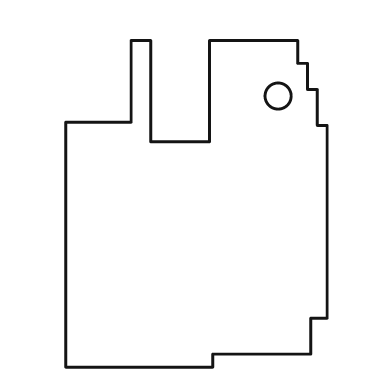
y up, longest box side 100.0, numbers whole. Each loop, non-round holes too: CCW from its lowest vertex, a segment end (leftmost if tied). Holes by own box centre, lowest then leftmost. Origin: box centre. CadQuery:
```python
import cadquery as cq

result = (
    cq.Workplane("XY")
    .moveTo(-40.0, -50.0)
    .lineTo(5.0, -50.0)
    .lineTo(5.0, -46.0)
    .lineTo(35.0, -46.0)
    .lineTo(35.0, -35.0)
    .lineTo(40.0, -35.0)
    .lineTo(40.0, 24.0)
    .lineTo(37.0, 24.0)
    .lineTo(37.0, 35.0)
    .lineTo(34.0, 35.0)
    .lineTo(34.0, 43.0)
    .lineTo(31.0, 43.0)
    .lineTo(31.0, 50.0)
    .lineTo(4.0, 50.0)
    .lineTo(4.0, 19.0)
    .lineTo(-14.0, 19.0)
    .lineTo(-14.0, 50.0)
    .lineTo(-20.0, 50.0)
    .lineTo(-20.0, 25.0)
    .lineTo(-40.0, 25.0)
    .close()
    .moveTo(25.0, 33.0)
    .circle(4.0)
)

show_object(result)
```